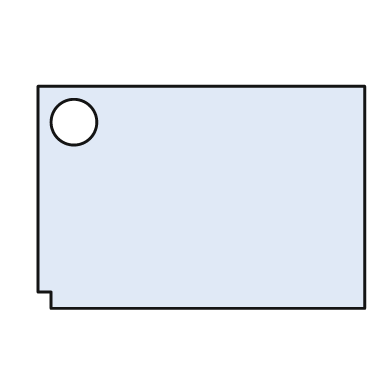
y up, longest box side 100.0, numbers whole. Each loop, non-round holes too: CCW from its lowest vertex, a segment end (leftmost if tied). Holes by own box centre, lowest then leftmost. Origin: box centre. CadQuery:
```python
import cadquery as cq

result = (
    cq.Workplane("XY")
    .moveTo(-46.0, -34.0)
    .lineTo(50.0, -34.0)
    .lineTo(50.0, 34.0)
    .lineTo(-50.0, 34.0)
    .lineTo(-50.0, -29.0)
    .lineTo(-46.0, -29.0)
    .close()
    .moveTo(-39.0, 23.0)
    .circle(7.0)
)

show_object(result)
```